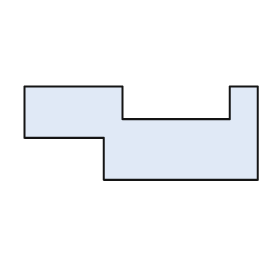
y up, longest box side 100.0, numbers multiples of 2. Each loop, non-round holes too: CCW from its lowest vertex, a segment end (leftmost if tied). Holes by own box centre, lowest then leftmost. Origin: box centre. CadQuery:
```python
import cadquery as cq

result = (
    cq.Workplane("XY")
    .moveTo(-16.0, -20.0)
    .lineTo(50.0, -20.0)
    .lineTo(50.0, 20.0)
    .lineTo(38.0, 20.0)
    .lineTo(38.0, 6.0)
    .lineTo(-8.0, 6.0)
    .lineTo(-8.0, 20.0)
    .lineTo(-50.0, 20.0)
    .lineTo(-50.0, -2.0)
    .lineTo(-16.0, -2.0)
    .close()
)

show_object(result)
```